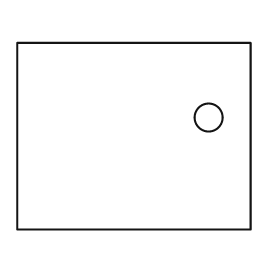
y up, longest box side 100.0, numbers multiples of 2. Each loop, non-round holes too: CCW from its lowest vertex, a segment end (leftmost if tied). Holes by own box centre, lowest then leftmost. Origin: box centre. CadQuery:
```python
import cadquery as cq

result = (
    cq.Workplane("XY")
    .moveTo(-50.0, -40.0)
    .lineTo(50.0, -40.0)
    .lineTo(50.0, 40.0)
    .lineTo(-50.0, 40.0)
    .close()
    .moveTo(32.0, 8.0)
    .circle(6.0)
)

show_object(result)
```